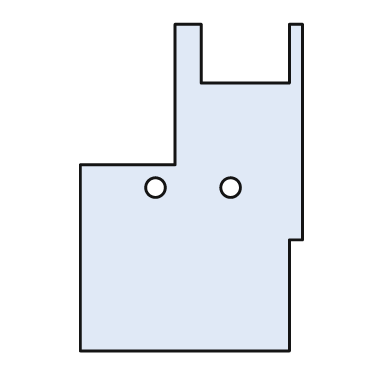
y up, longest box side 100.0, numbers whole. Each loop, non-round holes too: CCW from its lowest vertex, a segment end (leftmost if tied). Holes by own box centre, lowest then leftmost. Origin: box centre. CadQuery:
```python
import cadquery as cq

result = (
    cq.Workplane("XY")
    .moveTo(-34.0, -50.0)
    .lineTo(30.0, -50.0)
    .lineTo(30.0, -16.0)
    .lineTo(34.0, -16.0)
    .lineTo(34.0, 50.0)
    .lineTo(30.0, 50.0)
    .lineTo(30.0, 32.0)
    .lineTo(3.0, 32.0)
    .lineTo(3.0, 50.0)
    .lineTo(-5.0, 50.0)
    .lineTo(-5.0, 7.0)
    .lineTo(-34.0, 7.0)
    .close()
    .moveTo(-11.0, 0.0)
    .circle(3.0)
    .moveTo(12.0, 0.0)
    .circle(3.0)
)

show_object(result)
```